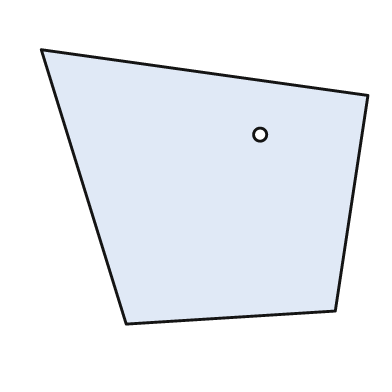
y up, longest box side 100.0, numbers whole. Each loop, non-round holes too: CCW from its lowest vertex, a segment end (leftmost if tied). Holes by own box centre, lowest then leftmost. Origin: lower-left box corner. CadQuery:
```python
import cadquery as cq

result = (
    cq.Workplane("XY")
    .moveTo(26.0, 0.0)
    .lineTo(90.0, 4.0)
    .lineTo(100.0, 70.0)
    .lineTo(0.0, 84.0)
    .close()
    .moveTo(67.0, 58.0)
    .circle(2.0)
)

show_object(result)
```